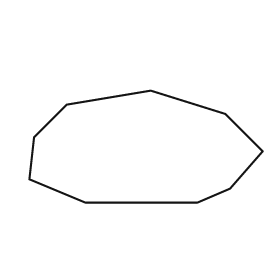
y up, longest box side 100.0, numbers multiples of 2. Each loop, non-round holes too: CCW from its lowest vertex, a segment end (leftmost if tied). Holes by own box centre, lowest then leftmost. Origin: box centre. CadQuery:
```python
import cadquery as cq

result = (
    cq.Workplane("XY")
    .moveTo(-26.0, -24.0)
    .lineTo(22.0, -24.0)
    .lineTo(36.0, -18.0)
    .lineTo(50.0, -2.0)
    .lineTo(34.0, 14.0)
    .lineTo(2.0, 24.0)
    .lineTo(-34.0, 18.0)
    .lineTo(-48.0, 4.0)
    .lineTo(-50.0, -14.0)
    .close()
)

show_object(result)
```